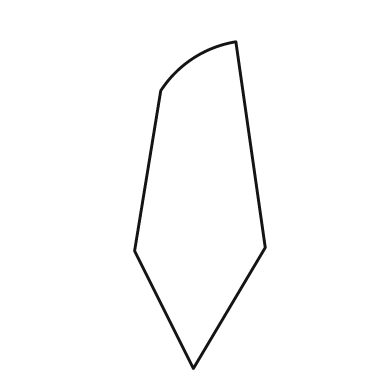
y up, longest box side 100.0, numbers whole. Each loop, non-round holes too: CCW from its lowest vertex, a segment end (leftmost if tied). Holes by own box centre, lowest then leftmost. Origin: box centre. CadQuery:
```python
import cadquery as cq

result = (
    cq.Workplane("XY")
    .moveTo(-2.0, -50.0)
    .lineTo(20.0, -13.0)
    .lineTo(11.0, 50.0)
    .threePointArc((-2.0, 45.0), (-12.0, 35.0))
    .lineTo(-20.0, -14.0)
    .close()
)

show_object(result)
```